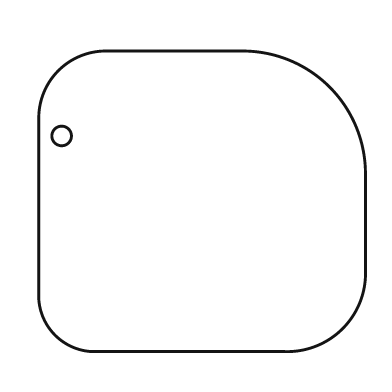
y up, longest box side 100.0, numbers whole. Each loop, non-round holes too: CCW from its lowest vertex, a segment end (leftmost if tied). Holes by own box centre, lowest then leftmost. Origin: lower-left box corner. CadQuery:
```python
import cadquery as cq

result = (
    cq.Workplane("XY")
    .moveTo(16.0, 0.0)
    .lineTo(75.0, 0.0)
    .threePointArc((93.0, 7.0), (100.0, 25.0))
    .lineTo(100.0, 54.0)
    .threePointArc((89.0, 81.0), (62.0, 92.0))
    .lineTo(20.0, 92.0)
    .threePointArc((6.0, 86.0), (0.0, 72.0))
    .lineTo(0.0, 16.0)
    .threePointArc((5.0, 5.0), (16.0, 0.0))
    .close()
    .moveTo(7.0, 66.0)
    .circle(3.0)
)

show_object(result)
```